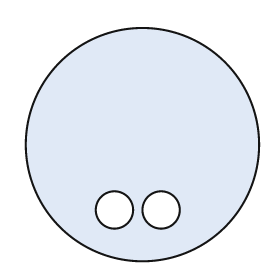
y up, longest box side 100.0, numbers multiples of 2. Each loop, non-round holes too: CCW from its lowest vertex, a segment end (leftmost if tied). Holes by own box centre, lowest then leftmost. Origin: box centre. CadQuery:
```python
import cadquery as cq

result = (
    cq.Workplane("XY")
    .moveTo(0.0, 0.0)
    .circle(50.0)
    .moveTo(-12.0, -28.0)
    .circle(8.0)
    .moveTo(8.0, -28.0)
    .circle(8.0)
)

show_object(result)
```